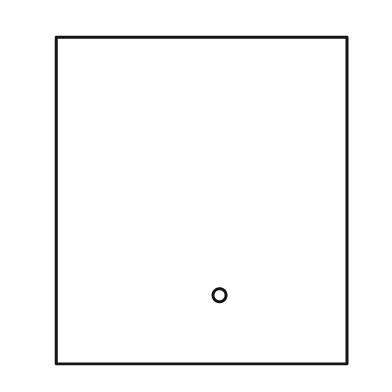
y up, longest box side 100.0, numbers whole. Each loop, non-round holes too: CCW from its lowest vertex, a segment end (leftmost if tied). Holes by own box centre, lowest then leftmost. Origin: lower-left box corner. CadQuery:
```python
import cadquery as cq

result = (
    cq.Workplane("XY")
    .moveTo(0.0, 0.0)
    .lineTo(89.0, 0.0)
    .lineTo(89.0, 100.0)
    .lineTo(0.0, 100.0)
    .close()
    .moveTo(50.0, 21.0)
    .circle(2.0)
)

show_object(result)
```